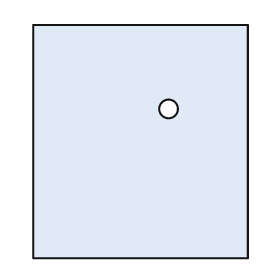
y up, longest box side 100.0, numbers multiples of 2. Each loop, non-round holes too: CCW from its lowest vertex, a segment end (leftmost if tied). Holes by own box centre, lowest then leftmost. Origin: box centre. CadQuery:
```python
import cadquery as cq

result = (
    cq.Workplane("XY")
    .moveTo(-46.0, -50.0)
    .lineTo(46.0, -50.0)
    .lineTo(46.0, 50.0)
    .lineTo(-46.0, 50.0)
    .close()
    .moveTo(12.0, 14.0)
    .circle(4.0)
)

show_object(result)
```